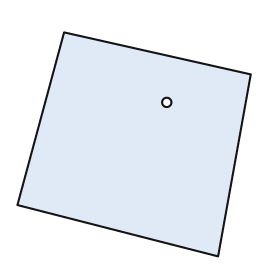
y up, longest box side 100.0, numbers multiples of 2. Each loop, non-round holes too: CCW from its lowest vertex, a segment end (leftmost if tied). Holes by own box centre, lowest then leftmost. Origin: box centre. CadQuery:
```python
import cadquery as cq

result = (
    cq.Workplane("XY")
    .moveTo(36.0, -48.0)
    .lineTo(50.0, 30.0)
    .lineTo(-30.0, 48.0)
    .lineTo(-50.0, -26.0)
    .close()
    .moveTo(14.0, 18.0)
    .circle(2.0)
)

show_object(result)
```